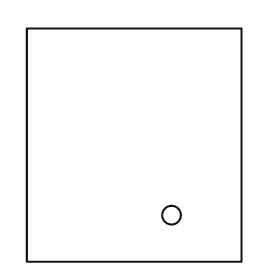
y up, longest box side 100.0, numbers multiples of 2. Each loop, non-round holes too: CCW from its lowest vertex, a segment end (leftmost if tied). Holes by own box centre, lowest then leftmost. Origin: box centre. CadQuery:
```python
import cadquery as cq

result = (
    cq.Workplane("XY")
    .moveTo(-46.0, -50.0)
    .lineTo(46.0, -50.0)
    .lineTo(46.0, 50.0)
    .lineTo(-46.0, 50.0)
    .close()
    .moveTo(16.0, -30.0)
    .circle(4.0)
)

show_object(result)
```